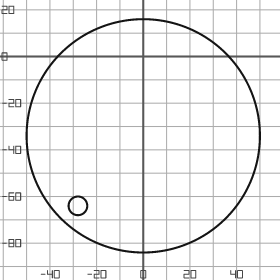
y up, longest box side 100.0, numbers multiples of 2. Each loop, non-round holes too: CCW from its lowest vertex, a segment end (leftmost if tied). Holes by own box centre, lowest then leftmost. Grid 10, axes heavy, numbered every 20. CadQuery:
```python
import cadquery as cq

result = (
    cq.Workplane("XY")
    .moveTo(0.0, -34.0)
    .circle(50.0)
    .moveTo(-28.0, -64.0)
    .circle(4.0)
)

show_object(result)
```